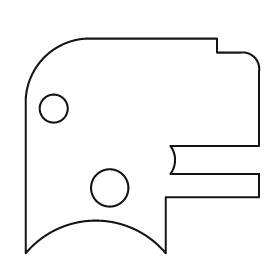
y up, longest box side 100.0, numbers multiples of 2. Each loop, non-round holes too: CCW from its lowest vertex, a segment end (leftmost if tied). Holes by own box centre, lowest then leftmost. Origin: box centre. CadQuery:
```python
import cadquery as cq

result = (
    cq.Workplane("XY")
    .moveTo(-50.0, -46.0)
    .threePointArc((-20.0, -32.0), (10.0, -46.0))
    .lineTo(10.0, -22.0)
    .lineTo(50.0, -22.0)
    .lineTo(50.0, -12.0)
    .lineTo(12.0, -12.0)
    .threePointArc((14.0, -6.0), (12.0, 0.0))
    .lineTo(50.0, 0.0)
    .lineTo(50.0, 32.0)
    .threePointArc((48.0, 38.0), (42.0, 40.0))
    .lineTo(32.0, 40.0)
    .lineTo(32.0, 46.0)
    .lineTo(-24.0, 46.0)
    .threePointArc((-42.0, 38.0), (-50.0, 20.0))
    .close()
    .moveTo(-14.0, -18.0)
    .circle(8.0)
    .moveTo(-38.0, 16.0)
    .circle(6.0)
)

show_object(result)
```